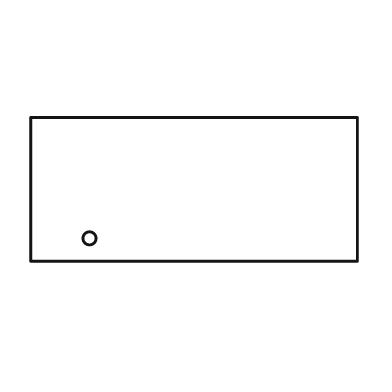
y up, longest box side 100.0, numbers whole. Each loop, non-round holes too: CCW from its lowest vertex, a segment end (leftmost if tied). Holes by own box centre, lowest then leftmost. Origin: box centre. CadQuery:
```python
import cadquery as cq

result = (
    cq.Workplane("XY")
    .moveTo(-50.0, -22.0)
    .lineTo(50.0, -22.0)
    .lineTo(50.0, 22.0)
    .lineTo(-50.0, 22.0)
    .close()
    .moveTo(-32.0, -15.0)
    .circle(2.0)
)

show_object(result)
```